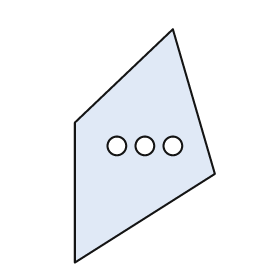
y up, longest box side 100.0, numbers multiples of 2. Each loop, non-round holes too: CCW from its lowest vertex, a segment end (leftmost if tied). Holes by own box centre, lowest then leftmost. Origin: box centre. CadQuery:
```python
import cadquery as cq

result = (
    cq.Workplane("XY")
    .moveTo(-30.0, -50.0)
    .lineTo(30.0, -12.0)
    .lineTo(12.0, 50.0)
    .lineTo(-30.0, 10.0)
    .close()
    .moveTo(-12.0, 0.0)
    .circle(4.0)
    .moveTo(0.0, 0.0)
    .circle(4.0)
    .moveTo(12.0, 0.0)
    .circle(4.0)
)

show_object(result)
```